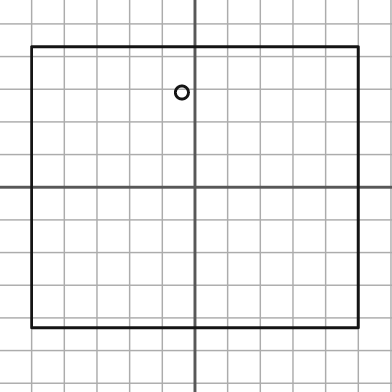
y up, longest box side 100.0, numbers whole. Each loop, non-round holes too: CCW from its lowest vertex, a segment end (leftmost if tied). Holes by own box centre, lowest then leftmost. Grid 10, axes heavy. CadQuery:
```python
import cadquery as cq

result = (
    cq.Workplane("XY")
    .moveTo(-50.0, -43.0)
    .lineTo(50.0, -43.0)
    .lineTo(50.0, 43.0)
    .lineTo(-50.0, 43.0)
    .close()
    .moveTo(-4.0, 29.0)
    .circle(2.0)
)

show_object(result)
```